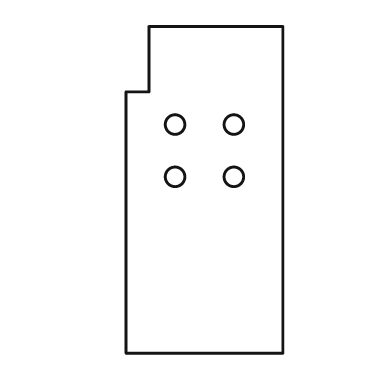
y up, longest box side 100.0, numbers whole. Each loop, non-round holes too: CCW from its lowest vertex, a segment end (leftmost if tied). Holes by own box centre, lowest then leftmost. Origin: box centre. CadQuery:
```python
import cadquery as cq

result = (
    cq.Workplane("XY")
    .moveTo(-24.0, -50.0)
    .lineTo(24.0, -50.0)
    .lineTo(24.0, 50.0)
    .lineTo(-17.0, 50.0)
    .lineTo(-17.0, 30.0)
    .lineTo(-24.0, 30.0)
    .close()
    .moveTo(-9.0, 4.0)
    .circle(3.0)
    .moveTo(9.0, 4.0)
    .circle(3.0)
    .moveTo(-9.0, 20.0)
    .circle(3.0)
    .moveTo(9.0, 20.0)
    .circle(3.0)
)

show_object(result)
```